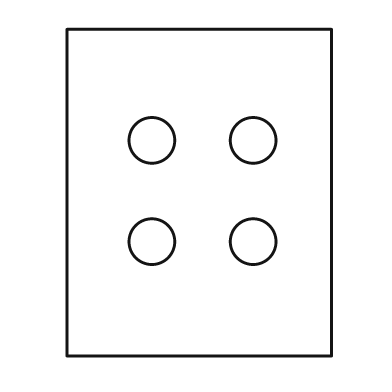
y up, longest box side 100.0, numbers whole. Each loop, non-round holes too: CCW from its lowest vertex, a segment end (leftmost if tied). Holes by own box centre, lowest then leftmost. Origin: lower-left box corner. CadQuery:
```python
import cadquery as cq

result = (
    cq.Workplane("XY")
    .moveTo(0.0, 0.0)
    .lineTo(81.0, 0.0)
    .lineTo(81.0, 100.0)
    .lineTo(0.0, 100.0)
    .close()
    .moveTo(26.0, 35.0)
    .circle(7.0)
    .moveTo(57.0, 35.0)
    .circle(7.0)
    .moveTo(26.0, 66.0)
    .circle(7.0)
    .moveTo(57.0, 66.0)
    .circle(7.0)
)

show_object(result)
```